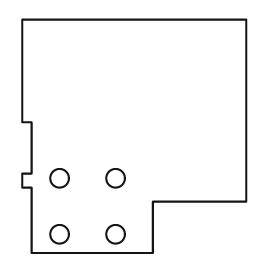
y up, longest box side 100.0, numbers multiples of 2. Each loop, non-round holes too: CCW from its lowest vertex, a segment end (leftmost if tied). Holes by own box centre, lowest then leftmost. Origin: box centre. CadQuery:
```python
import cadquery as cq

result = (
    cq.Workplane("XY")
    .moveTo(-44.0, -50.0)
    .lineTo(8.0, -50.0)
    .lineTo(8.0, -28.0)
    .lineTo(48.0, -28.0)
    .lineTo(48.0, 50.0)
    .lineTo(-48.0, 50.0)
    .lineTo(-48.0, 6.0)
    .lineTo(-44.0, 6.0)
    .lineTo(-44.0, -16.0)
    .lineTo(-48.0, -16.0)
    .lineTo(-48.0, -22.0)
    .lineTo(-44.0, -22.0)
    .close()
    .moveTo(-32.0, -42.0)
    .circle(4.0)
    .moveTo(-8.0, -42.0)
    .circle(4.0)
    .moveTo(-32.0, -18.0)
    .circle(4.0)
    .moveTo(-8.0, -18.0)
    .circle(4.0)
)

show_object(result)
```